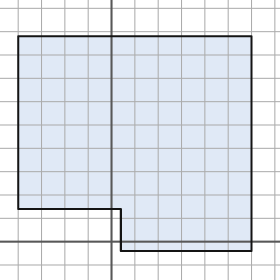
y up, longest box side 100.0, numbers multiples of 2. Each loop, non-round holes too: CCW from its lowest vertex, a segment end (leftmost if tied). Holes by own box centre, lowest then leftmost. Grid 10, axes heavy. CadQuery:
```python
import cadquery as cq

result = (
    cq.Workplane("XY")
    .moveTo(4.0, -4.0)
    .lineTo(60.0, -4.0)
    .lineTo(60.0, 88.0)
    .lineTo(-40.0, 88.0)
    .lineTo(-40.0, 14.0)
    .lineTo(4.0, 14.0)
    .close()
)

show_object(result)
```